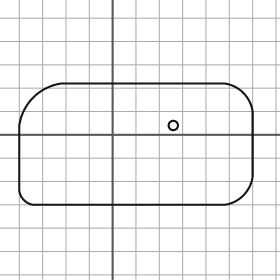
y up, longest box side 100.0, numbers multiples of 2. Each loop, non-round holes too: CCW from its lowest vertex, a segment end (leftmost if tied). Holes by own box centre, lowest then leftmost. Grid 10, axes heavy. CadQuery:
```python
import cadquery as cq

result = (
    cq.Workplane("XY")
    .moveTo(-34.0, -30.0)
    .lineTo(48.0, -30.0)
    .threePointArc((56.0, -26.0), (60.0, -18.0))
    .lineTo(60.0, 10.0)
    .threePointArc((56.0, 18.0), (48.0, 22.0))
    .lineTo(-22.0, 22.0)
    .threePointArc((-34.0, 16.0), (-40.0, 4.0))
    .lineTo(-40.0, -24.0)
    .threePointArc((-38.0, -28.0), (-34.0, -30.0))
    .close()
    .moveTo(26.0, 4.0)
    .circle(2.0)
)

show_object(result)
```